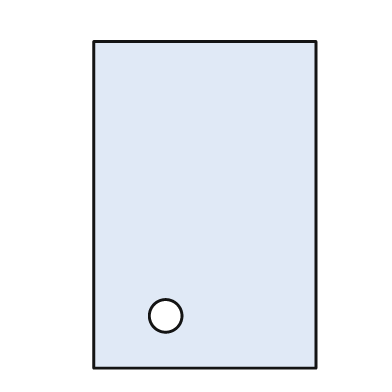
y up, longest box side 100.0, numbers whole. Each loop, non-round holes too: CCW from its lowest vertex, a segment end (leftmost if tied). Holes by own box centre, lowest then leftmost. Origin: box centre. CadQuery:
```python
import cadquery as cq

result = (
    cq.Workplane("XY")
    .moveTo(-34.0, -50.0)
    .lineTo(34.0, -50.0)
    .lineTo(34.0, 50.0)
    .lineTo(-34.0, 50.0)
    .close()
    .moveTo(-12.0, -34.0)
    .circle(5.0)
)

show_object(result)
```